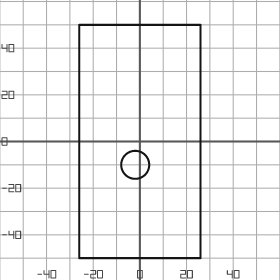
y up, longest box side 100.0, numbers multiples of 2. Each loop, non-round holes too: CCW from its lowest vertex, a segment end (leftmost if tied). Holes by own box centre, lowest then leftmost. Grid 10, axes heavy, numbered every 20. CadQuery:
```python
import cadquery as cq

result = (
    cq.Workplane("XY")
    .moveTo(-26.0, -50.0)
    .lineTo(26.0, -50.0)
    .lineTo(26.0, 50.0)
    .lineTo(-26.0, 50.0)
    .close()
    .moveTo(-2.0, -10.0)
    .circle(6.0)
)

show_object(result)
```